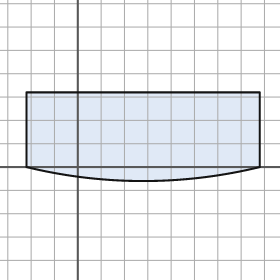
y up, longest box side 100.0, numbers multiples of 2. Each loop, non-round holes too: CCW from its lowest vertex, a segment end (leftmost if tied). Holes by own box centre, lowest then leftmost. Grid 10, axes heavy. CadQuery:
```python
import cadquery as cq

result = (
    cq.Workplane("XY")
    .moveTo(-22.0, 0.0)
    .threePointArc((28.0, -6.0), (78.0, 0.0))
    .lineTo(78.0, 32.0)
    .lineTo(-22.0, 32.0)
    .close()
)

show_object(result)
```